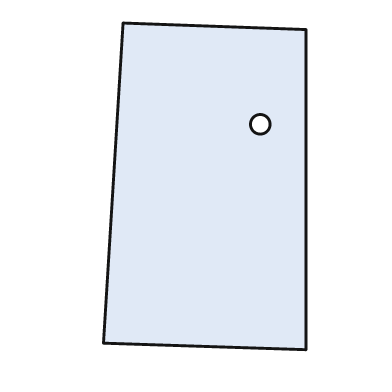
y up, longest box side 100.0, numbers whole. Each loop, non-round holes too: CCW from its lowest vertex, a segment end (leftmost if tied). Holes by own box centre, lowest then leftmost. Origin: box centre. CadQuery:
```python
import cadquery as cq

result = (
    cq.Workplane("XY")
    .moveTo(31.0, -50.0)
    .lineTo(31.0, 48.0)
    .lineTo(-25.0, 50.0)
    .lineTo(-31.0, -48.0)
    .close()
    .moveTo(17.0, 19.0)
    .circle(3.0)
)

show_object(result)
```